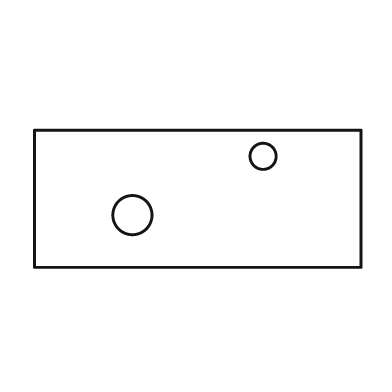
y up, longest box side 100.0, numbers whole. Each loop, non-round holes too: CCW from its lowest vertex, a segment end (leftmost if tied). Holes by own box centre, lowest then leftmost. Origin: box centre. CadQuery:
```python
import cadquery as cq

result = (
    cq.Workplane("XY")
    .moveTo(-50.0, -21.0)
    .lineTo(50.0, -21.0)
    .lineTo(50.0, 21.0)
    .lineTo(-50.0, 21.0)
    .close()
    .moveTo(-20.0, -5.0)
    .circle(6.0)
    .moveTo(20.0, 13.0)
    .circle(4.0)
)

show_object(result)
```